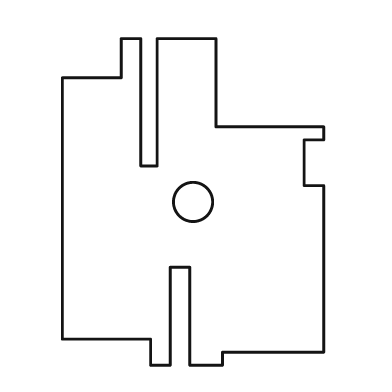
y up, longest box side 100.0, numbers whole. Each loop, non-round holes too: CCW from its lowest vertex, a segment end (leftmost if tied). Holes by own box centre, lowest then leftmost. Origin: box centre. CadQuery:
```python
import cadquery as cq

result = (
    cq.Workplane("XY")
    .moveTo(-13.0, -50.0)
    .lineTo(-7.0, -50.0)
    .lineTo(-7.0, -20.0)
    .lineTo(-1.0, -20.0)
    .lineTo(-1.0, -50.0)
    .lineTo(9.0, -50.0)
    .lineTo(9.0, -46.0)
    .lineTo(40.0, -46.0)
    .lineTo(40.0, 5.0)
    .lineTo(34.0, 5.0)
    .lineTo(34.0, 19.0)
    .lineTo(40.0, 19.0)
    .lineTo(40.0, 23.0)
    .lineTo(7.0, 23.0)
    .lineTo(7.0, 50.0)
    .lineTo(-11.0, 50.0)
    .lineTo(-11.0, 11.0)
    .lineTo(-16.0, 11.0)
    .lineTo(-16.0, 50.0)
    .lineTo(-22.0, 50.0)
    .lineTo(-22.0, 38.0)
    .lineTo(-40.0, 38.0)
    .lineTo(-40.0, -42.0)
    .lineTo(-13.0, -42.0)
    .close()
    .moveTo(0.0, 0.0)
    .circle(6.0)
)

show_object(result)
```